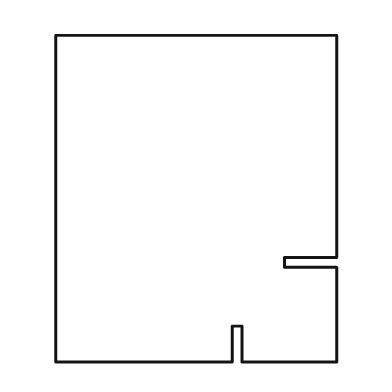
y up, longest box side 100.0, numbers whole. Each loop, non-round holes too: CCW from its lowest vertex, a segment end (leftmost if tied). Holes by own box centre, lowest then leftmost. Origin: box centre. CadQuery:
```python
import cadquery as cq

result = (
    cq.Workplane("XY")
    .moveTo(-43.0, -50.0)
    .lineTo(11.0, -50.0)
    .lineTo(11.0, -39.0)
    .lineTo(14.0, -39.0)
    .lineTo(14.0, -50.0)
    .lineTo(43.0, -50.0)
    .lineTo(43.0, -21.0)
    .lineTo(27.0, -21.0)
    .lineTo(27.0, -18.0)
    .lineTo(43.0, -18.0)
    .lineTo(43.0, 50.0)
    .lineTo(-43.0, 50.0)
    .close()
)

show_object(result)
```